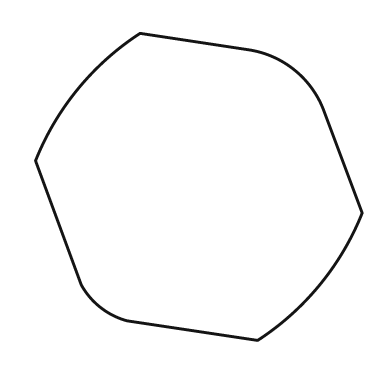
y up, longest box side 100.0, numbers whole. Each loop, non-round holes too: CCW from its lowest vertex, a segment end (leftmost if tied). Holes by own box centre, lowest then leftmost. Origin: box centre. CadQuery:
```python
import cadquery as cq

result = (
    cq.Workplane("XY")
    .moveTo(18.0, -47.0)
    .threePointArc((37.0, -30.0), (50.0, -8.0))
    .lineTo(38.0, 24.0)
    .threePointArc((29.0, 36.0), (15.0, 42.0))
    .lineTo(-18.0, 47.0)
    .threePointArc((-37.0, 30.0), (-50.0, 8.0))
    .lineTo(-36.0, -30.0)
    .threePointArc((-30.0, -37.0), (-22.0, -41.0))
    .close()
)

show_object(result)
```